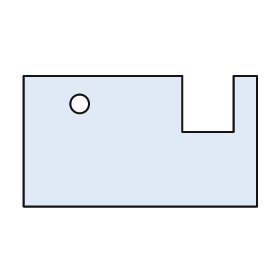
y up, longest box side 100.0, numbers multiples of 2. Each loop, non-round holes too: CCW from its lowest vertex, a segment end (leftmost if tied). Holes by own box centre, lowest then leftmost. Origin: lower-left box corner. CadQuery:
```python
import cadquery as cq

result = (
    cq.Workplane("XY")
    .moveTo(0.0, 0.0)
    .lineTo(100.0, 0.0)
    .lineTo(100.0, 56.0)
    .lineTo(90.0, 56.0)
    .lineTo(90.0, 32.0)
    .lineTo(68.0, 32.0)
    .lineTo(68.0, 56.0)
    .lineTo(0.0, 56.0)
    .close()
    .moveTo(24.0, 44.0)
    .circle(4.0)
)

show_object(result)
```